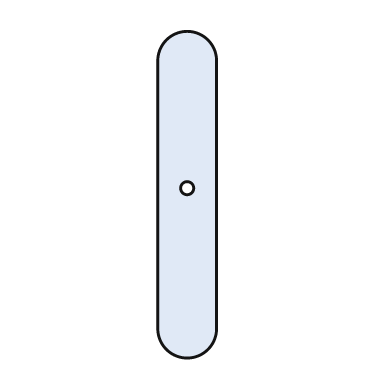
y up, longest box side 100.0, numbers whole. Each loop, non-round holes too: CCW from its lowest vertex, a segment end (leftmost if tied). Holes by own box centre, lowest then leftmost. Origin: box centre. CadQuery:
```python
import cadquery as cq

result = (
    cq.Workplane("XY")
    .moveTo(-9.0, -41.0)
    .threePointArc((0.0, -50.0), (9.0, -41.0))
    .lineTo(9.0, 41.0)
    .threePointArc((0.0, 50.0), (-9.0, 41.0))
    .close()
    .moveTo(0.0, 2.0)
    .circle(2.0)
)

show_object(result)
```